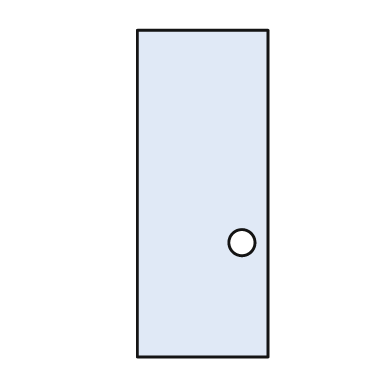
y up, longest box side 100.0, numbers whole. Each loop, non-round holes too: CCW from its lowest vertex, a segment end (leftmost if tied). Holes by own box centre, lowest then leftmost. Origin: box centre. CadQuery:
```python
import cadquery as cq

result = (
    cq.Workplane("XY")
    .moveTo(-20.0, -50.0)
    .lineTo(20.0, -50.0)
    .lineTo(20.0, 50.0)
    .lineTo(-20.0, 50.0)
    .close()
    .moveTo(12.0, -15.0)
    .circle(4.0)
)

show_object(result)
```